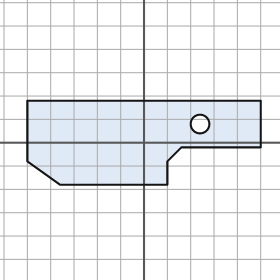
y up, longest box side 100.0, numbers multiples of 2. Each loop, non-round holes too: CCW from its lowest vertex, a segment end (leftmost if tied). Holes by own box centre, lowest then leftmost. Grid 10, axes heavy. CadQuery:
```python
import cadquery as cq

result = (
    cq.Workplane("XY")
    .moveTo(-36.0, -18.0)
    .lineTo(10.0, -18.0)
    .lineTo(10.0, -8.0)
    .lineTo(16.0, -2.0)
    .lineTo(50.0, -2.0)
    .lineTo(50.0, 18.0)
    .lineTo(-50.0, 18.0)
    .lineTo(-50.0, -8.0)
    .close()
    .moveTo(24.0, 8.0)
    .circle(4.0)
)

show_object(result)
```